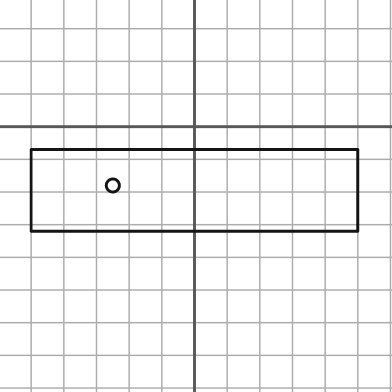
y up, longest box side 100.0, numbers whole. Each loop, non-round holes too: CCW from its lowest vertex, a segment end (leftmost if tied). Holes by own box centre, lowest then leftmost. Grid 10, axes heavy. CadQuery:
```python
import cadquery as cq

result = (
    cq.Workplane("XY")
    .moveTo(-50.0, -32.0)
    .lineTo(50.0, -32.0)
    .lineTo(50.0, -7.0)
    .lineTo(-50.0, -7.0)
    .close()
    .moveTo(-25.0, -18.0)
    .circle(2.0)
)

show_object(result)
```